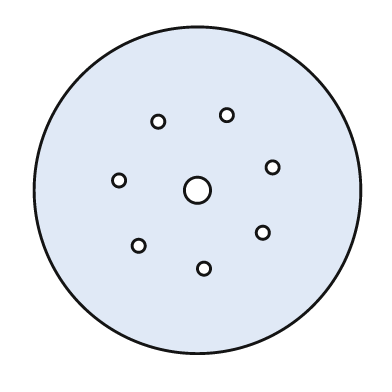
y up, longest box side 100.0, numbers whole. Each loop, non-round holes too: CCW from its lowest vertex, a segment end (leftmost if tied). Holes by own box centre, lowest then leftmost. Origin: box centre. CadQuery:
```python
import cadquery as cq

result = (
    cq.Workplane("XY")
    .moveTo(0.0, 0.0)
    .circle(50.0)
    .moveTo(2.0, -24.0)
    .circle(2.0)
    .moveTo(-18.0, -17.0)
    .circle(2.0)
    .moveTo(20.0, -13.0)
    .circle(2.0)
    .moveTo(0.0, 0.0)
    .circle(4.0)
    .moveTo(-24.0, 3.0)
    .circle(2.0)
    .moveTo(23.0, 7.0)
    .circle(2.0)
    .moveTo(-12.0, 21.0)
    .circle(2.0)
    .moveTo(9.0, 23.0)
    .circle(2.0)
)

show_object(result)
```